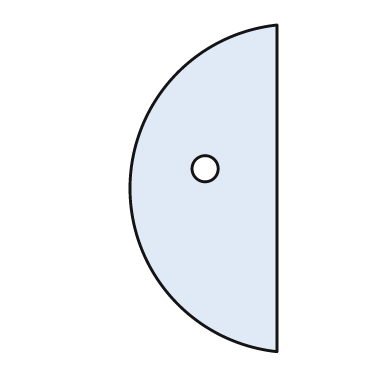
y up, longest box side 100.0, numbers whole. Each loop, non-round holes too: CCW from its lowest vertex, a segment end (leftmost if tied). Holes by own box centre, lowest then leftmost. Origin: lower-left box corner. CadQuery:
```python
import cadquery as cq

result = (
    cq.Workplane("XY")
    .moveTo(45.0, 0.0)
    .lineTo(45.0, 100.0)
    .threePointArc((0.0, 50.0), (45.0, 0.0))
    .close()
    .moveTo(23.0, 56.0)
    .circle(4.0)
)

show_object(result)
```